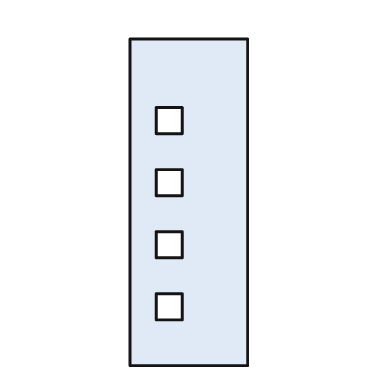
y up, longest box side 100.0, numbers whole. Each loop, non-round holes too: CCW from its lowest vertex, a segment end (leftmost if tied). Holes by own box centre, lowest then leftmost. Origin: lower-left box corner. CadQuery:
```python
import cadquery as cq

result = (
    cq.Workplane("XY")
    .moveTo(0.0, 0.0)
    .lineTo(36.0, 0.0)
    .lineTo(36.0, 100.0)
    .lineTo(0.0, 100.0)
    .close()
    .moveTo(8.0, 14.0)
    .lineTo(16.0, 14.0)
    .lineTo(16.0, 22.0)
    .lineTo(8.0, 22.0)
    .close()
    .moveTo(8.0, 33.0)
    .lineTo(16.0, 33.0)
    .lineTo(16.0, 41.0)
    .lineTo(8.0, 41.0)
    .close()
    .moveTo(8.0, 52.0)
    .lineTo(16.0, 52.0)
    .lineTo(16.0, 60.0)
    .lineTo(8.0, 60.0)
    .close()
    .moveTo(8.0, 71.0)
    .lineTo(16.0, 71.0)
    .lineTo(16.0, 79.0)
    .lineTo(8.0, 79.0)
    .close()
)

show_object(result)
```